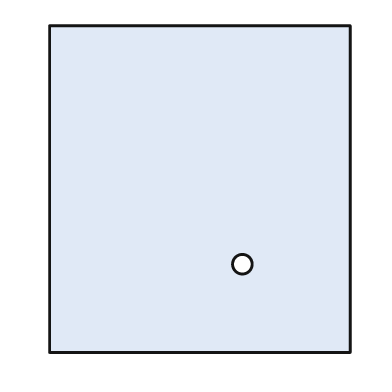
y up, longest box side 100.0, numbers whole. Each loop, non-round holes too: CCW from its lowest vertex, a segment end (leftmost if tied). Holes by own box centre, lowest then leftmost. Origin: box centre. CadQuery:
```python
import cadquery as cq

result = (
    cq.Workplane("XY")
    .moveTo(-46.0, -50.0)
    .lineTo(46.0, -50.0)
    .lineTo(46.0, 50.0)
    .lineTo(-46.0, 50.0)
    .close()
    .moveTo(13.0, -23.0)
    .circle(3.0)
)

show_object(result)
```